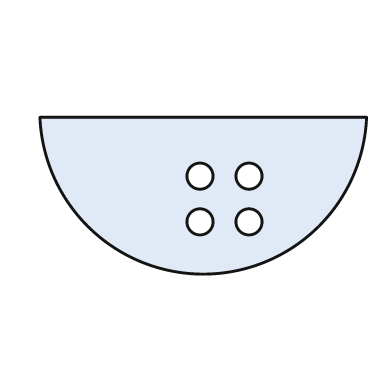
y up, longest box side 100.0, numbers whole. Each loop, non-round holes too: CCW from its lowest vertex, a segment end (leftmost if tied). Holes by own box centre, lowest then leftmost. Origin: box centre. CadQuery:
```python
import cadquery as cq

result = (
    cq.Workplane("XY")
    .moveTo(-50.0, 24.0)
    .threePointArc((0.0, -24.0), (50.0, 24.0))
    .close()
    .moveTo(-1.0, -8.0)
    .circle(4.0)
    .moveTo(14.0, -8.0)
    .circle(4.0)
    .moveTo(-1.0, 6.0)
    .circle(4.0)
    .moveTo(14.0, 6.0)
    .circle(4.0)
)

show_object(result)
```